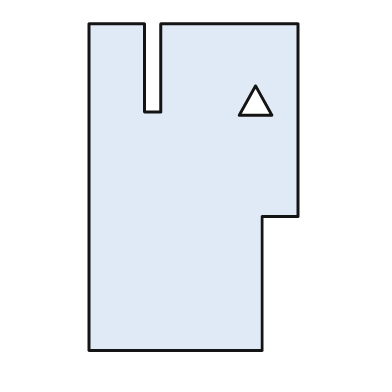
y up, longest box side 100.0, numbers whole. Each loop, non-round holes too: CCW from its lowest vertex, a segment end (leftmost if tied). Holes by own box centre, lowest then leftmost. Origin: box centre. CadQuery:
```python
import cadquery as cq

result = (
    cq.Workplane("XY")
    .moveTo(-32.0, -50.0)
    .lineTo(21.0, -50.0)
    .lineTo(21.0, -9.0)
    .lineTo(32.0, -9.0)
    .lineTo(32.0, 50.0)
    .lineTo(-10.0, 50.0)
    .lineTo(-10.0, 23.0)
    .lineTo(-15.0, 23.0)
    .lineTo(-15.0, 50.0)
    .lineTo(-32.0, 50.0)
    .close()
    .moveTo(14.0, 22.0)
    .lineTo(24.0, 22.0)
    .lineTo(19.0, 31.0)
    .close()
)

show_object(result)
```